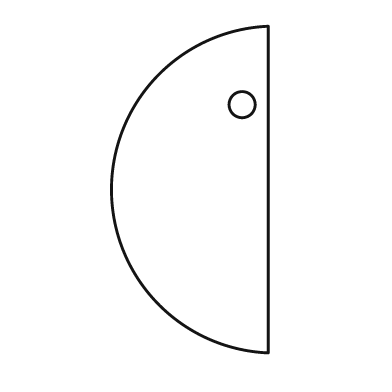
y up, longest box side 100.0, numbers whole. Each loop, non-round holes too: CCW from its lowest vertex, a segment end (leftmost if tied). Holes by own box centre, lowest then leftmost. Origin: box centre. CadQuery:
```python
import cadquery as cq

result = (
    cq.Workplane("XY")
    .moveTo(24.0, -50.0)
    .lineTo(24.0, 50.0)
    .threePointArc((-24.0, 0.0), (24.0, -50.0))
    .close()
    .moveTo(16.0, 26.0)
    .circle(4.0)
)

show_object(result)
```